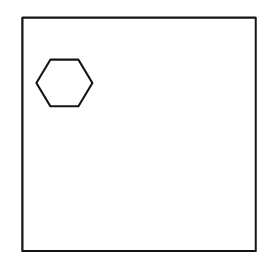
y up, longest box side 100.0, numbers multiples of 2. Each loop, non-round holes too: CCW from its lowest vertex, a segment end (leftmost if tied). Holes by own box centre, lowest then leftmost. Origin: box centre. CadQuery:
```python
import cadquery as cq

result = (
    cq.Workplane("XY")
    .moveTo(-50.0, -50.0)
    .lineTo(50.0, -50.0)
    .lineTo(50.0, 50.0)
    .lineTo(-50.0, 50.0)
    .close()
    .moveTo(-38.0, 12.0)
    .lineTo(-26.0, 12.0)
    .lineTo(-20.0, 22.0)
    .lineTo(-26.0, 32.0)
    .lineTo(-38.0, 32.0)
    .lineTo(-44.0, 22.0)
    .close()
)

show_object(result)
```